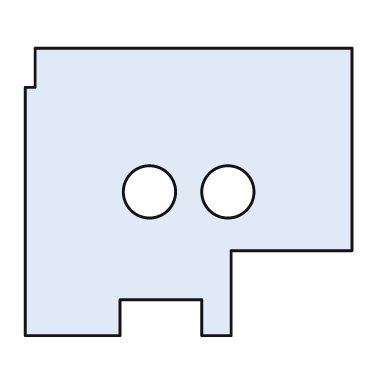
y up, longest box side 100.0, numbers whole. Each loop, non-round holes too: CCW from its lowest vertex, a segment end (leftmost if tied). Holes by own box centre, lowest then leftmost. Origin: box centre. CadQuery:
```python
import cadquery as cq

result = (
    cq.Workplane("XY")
    .moveTo(-50.0, -44.0)
    .lineTo(-21.0, -44.0)
    .lineTo(-21.0, -33.0)
    .lineTo(4.0, -33.0)
    .lineTo(4.0, -44.0)
    .lineTo(13.0, -44.0)
    .lineTo(13.0, -18.0)
    .lineTo(50.0, -18.0)
    .lineTo(50.0, 44.0)
    .lineTo(-47.0, 44.0)
    .lineTo(-47.0, 32.0)
    .lineTo(-50.0, 32.0)
    .close()
    .moveTo(-12.0, 0.0)
    .circle(8.0)
    .moveTo(12.0, 0.0)
    .circle(8.0)
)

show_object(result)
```